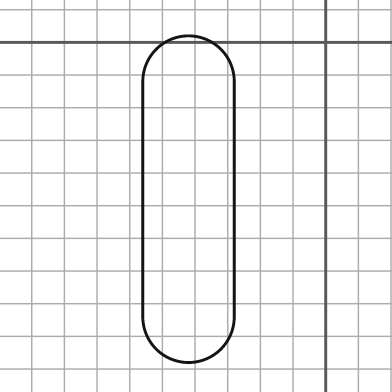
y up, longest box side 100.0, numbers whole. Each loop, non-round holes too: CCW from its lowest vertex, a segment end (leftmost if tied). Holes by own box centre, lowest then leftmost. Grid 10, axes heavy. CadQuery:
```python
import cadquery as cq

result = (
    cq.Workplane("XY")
    .moveTo(-56.0, -84.0)
    .threePointArc((-42.0, -98.0), (-28.0, -84.0))
    .lineTo(-28.0, -12.0)
    .threePointArc((-42.0, 2.0), (-56.0, -12.0))
    .close()
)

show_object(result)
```